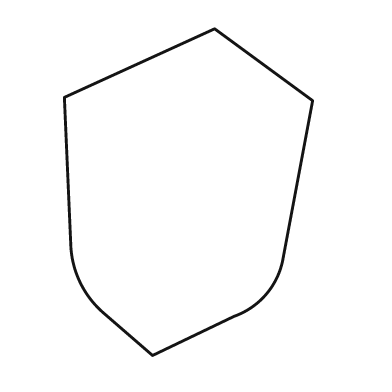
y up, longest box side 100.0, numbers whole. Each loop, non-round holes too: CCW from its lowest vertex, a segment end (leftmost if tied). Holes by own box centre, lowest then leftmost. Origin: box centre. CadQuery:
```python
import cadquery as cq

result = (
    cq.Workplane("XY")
    .moveTo(-11.0, -50.0)
    .lineTo(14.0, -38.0)
    .threePointArc((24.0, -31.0), (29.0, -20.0))
    .lineTo(38.0, 28.0)
    .lineTo(8.0, 50.0)
    .lineTo(-38.0, 29.0)
    .lineTo(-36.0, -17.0)
    .threePointArc((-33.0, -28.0), (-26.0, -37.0))
    .close()
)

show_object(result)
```